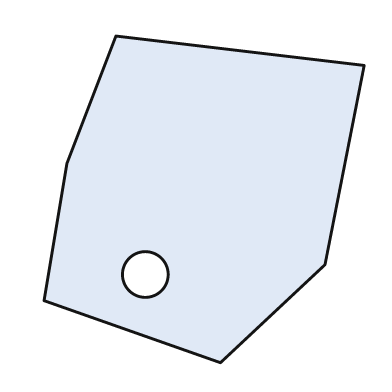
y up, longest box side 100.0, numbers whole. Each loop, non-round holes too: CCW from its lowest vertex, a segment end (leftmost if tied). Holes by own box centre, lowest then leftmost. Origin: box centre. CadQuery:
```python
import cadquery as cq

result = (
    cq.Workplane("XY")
    .moveTo(5.0, -50.0)
    .lineTo(37.0, -20.0)
    .lineTo(49.0, 41.0)
    .lineTo(-27.0, 50.0)
    .lineTo(-42.0, 11.0)
    .lineTo(-49.0, -31.0)
    .close()
    .moveTo(-18.0, -23.0)
    .circle(7.0)
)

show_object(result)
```